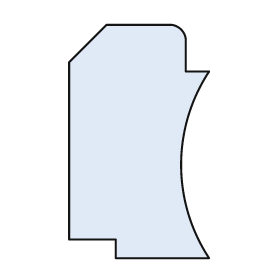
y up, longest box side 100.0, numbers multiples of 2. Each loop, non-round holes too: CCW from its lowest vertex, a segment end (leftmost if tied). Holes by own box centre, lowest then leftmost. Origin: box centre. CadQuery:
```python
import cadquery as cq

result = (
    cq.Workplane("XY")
    .moveTo(-10.0, -50.0)
    .lineTo(30.0, -50.0)
    .threePointArc((18.0, -10.0), (30.0, 30.0))
    .lineTo(20.0, 30.0)
    .lineTo(20.0, 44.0)
    .threePointArc((18.0, 48.0), (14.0, 50.0))
    .lineTo(-14.0, 50.0)
    .lineTo(-30.0, 34.0)
    .lineTo(-30.0, -42.0)
    .lineTo(-10.0, -42.0)
    .close()
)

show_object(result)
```